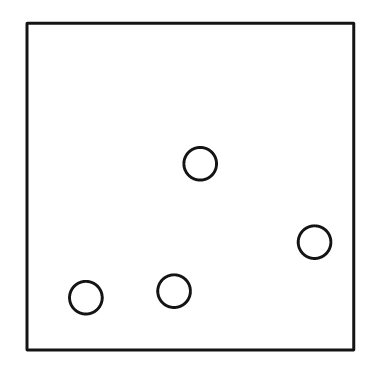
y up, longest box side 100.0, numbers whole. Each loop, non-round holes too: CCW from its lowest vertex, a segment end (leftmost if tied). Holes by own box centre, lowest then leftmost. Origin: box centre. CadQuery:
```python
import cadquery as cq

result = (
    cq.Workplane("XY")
    .moveTo(-50.0, -50.0)
    .lineTo(50.0, -50.0)
    .lineTo(50.0, 50.0)
    .lineTo(-50.0, 50.0)
    .close()
    .moveTo(-32.0, -34.0)
    .circle(5.0)
    .moveTo(-5.0, -32.0)
    .circle(5.0)
    .moveTo(38.0, -17.0)
    .circle(5.0)
    .moveTo(3.0, 7.0)
    .circle(5.0)
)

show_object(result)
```